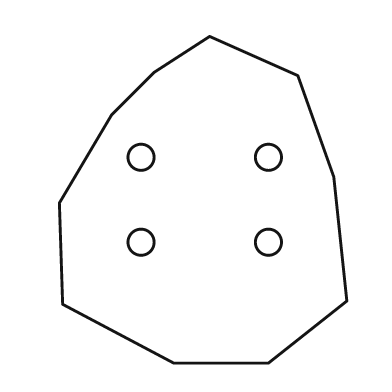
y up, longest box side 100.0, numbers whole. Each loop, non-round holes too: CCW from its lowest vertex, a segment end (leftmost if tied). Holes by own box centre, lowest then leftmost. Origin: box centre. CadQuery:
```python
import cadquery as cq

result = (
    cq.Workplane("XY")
    .moveTo(-9.0, -50.0)
    .lineTo(20.0, -50.0)
    .lineTo(44.0, -31.0)
    .lineTo(40.0, 7.0)
    .lineTo(29.0, 38.0)
    .lineTo(2.0, 50.0)
    .lineTo(-15.0, 39.0)
    .lineTo(-28.0, 26.0)
    .lineTo(-44.0, -1.0)
    .lineTo(-43.0, -32.0)
    .close()
    .moveTo(-19.0, -13.0)
    .circle(4.0)
    .moveTo(20.0, -13.0)
    .circle(4.0)
    .moveTo(-19.0, 13.0)
    .circle(4.0)
    .moveTo(20.0, 13.0)
    .circle(4.0)
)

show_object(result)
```